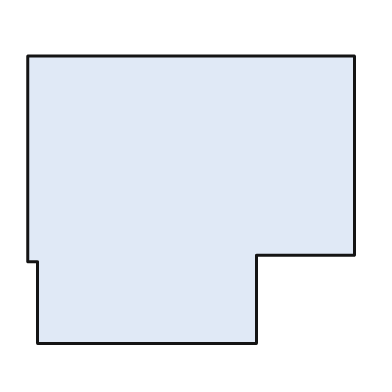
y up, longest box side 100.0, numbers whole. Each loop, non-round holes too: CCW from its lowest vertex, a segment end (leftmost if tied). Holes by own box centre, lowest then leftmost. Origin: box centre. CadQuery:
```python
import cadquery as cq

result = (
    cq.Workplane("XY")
    .moveTo(-47.0, -44.0)
    .lineTo(20.0, -44.0)
    .lineTo(20.0, -17.0)
    .lineTo(50.0, -17.0)
    .lineTo(50.0, 44.0)
    .lineTo(-50.0, 44.0)
    .lineTo(-50.0, -19.0)
    .lineTo(-47.0, -19.0)
    .close()
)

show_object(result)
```